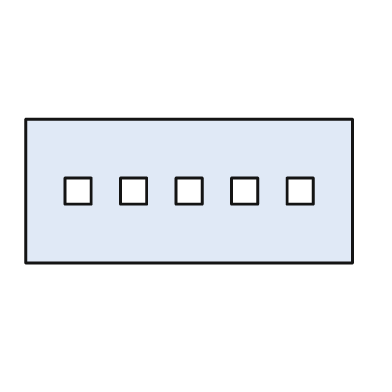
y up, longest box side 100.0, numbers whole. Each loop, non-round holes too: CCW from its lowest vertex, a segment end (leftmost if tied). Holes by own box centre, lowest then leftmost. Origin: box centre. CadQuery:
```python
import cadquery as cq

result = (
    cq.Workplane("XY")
    .moveTo(-50.0, -22.0)
    .lineTo(50.0, -22.0)
    .lineTo(50.0, 22.0)
    .lineTo(-50.0, 22.0)
    .close()
    .moveTo(-38.0, -4.0)
    .lineTo(-30.0, -4.0)
    .lineTo(-30.0, 4.0)
    .lineTo(-38.0, 4.0)
    .close()
    .moveTo(-21.0, -4.0)
    .lineTo(-13.0, -4.0)
    .lineTo(-13.0, 4.0)
    .lineTo(-21.0, 4.0)
    .close()
    .moveTo(-4.0, -4.0)
    .lineTo(4.0, -4.0)
    .lineTo(4.0, 4.0)
    .lineTo(-4.0, 4.0)
    .close()
    .moveTo(13.0, -4.0)
    .lineTo(21.0, -4.0)
    .lineTo(21.0, 4.0)
    .lineTo(13.0, 4.0)
    .close()
    .moveTo(30.0, -4.0)
    .lineTo(38.0, -4.0)
    .lineTo(38.0, 4.0)
    .lineTo(30.0, 4.0)
    .close()
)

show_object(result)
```